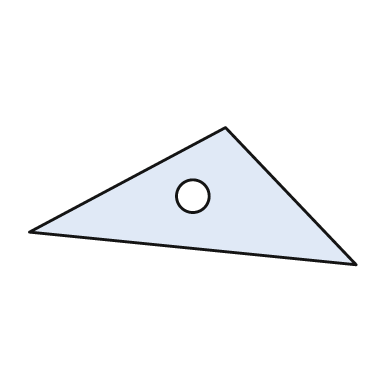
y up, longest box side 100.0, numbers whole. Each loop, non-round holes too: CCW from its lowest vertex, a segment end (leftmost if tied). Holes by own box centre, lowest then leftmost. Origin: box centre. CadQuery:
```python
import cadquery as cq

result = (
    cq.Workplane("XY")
    .moveTo(50.0, -21.0)
    .lineTo(10.0, 21.0)
    .lineTo(-50.0, -11.0)
    .close()
    .moveTo(0.0, 0.0)
    .circle(5.0)
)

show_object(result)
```